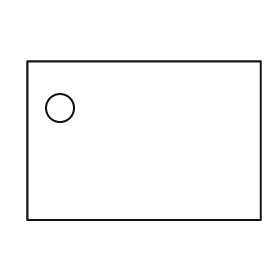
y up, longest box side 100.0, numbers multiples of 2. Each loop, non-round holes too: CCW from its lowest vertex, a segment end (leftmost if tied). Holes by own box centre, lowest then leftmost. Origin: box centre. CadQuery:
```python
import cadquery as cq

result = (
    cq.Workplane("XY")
    .moveTo(-50.0, -34.0)
    .lineTo(50.0, -34.0)
    .lineTo(50.0, 34.0)
    .lineTo(-50.0, 34.0)
    .close()
    .moveTo(-36.0, 14.0)
    .circle(6.0)
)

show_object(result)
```